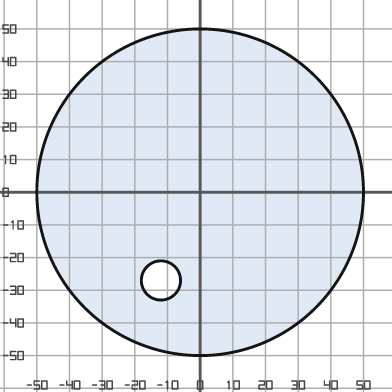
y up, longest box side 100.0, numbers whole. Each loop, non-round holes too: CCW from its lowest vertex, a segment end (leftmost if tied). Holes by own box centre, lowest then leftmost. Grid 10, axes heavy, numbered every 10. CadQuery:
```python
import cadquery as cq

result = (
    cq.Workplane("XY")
    .moveTo(0.0, 0.0)
    .circle(50.0)
    .moveTo(-12.0, -27.0)
    .circle(6.0)
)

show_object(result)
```